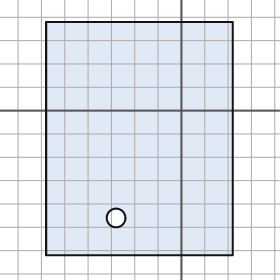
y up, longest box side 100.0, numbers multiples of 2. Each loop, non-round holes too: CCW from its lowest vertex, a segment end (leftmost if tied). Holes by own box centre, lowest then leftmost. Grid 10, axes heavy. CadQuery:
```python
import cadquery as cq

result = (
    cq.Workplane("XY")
    .moveTo(-58.0, -62.0)
    .lineTo(22.0, -62.0)
    .lineTo(22.0, 38.0)
    .lineTo(-58.0, 38.0)
    .close()
    .moveTo(-28.0, -46.0)
    .circle(4.0)
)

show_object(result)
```